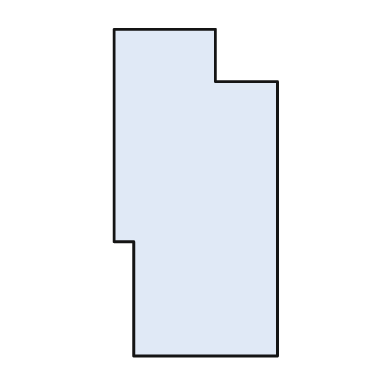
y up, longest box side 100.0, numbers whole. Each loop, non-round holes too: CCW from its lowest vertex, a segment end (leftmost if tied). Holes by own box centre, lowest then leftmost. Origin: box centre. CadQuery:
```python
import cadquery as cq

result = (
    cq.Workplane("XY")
    .moveTo(-19.0, -50.0)
    .lineTo(25.0, -50.0)
    .lineTo(25.0, 34.0)
    .lineTo(6.0, 34.0)
    .lineTo(6.0, 50.0)
    .lineTo(-25.0, 50.0)
    .lineTo(-25.0, -15.0)
    .lineTo(-19.0, -15.0)
    .close()
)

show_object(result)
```